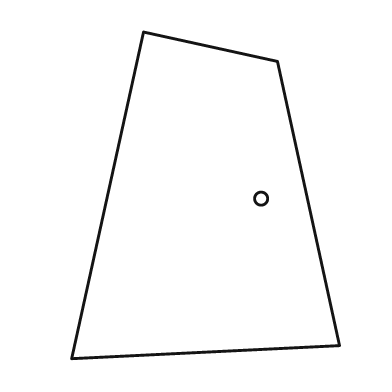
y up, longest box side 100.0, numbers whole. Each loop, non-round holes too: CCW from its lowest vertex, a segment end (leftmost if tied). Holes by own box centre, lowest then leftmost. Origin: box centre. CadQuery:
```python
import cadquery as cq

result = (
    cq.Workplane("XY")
    .moveTo(-41.0, -50.0)
    .lineTo(41.0, -46.0)
    .lineTo(22.0, 41.0)
    .lineTo(-19.0, 50.0)
    .close()
    .moveTo(17.0, -1.0)
    .circle(2.0)
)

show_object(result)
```